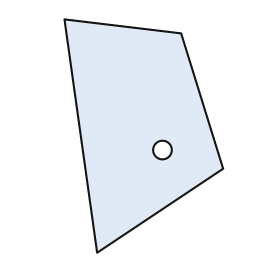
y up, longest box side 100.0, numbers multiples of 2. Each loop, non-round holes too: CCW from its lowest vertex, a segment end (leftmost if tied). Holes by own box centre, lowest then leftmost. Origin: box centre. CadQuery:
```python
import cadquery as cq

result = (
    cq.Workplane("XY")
    .moveTo(-20.0, -50.0)
    .lineTo(34.0, -14.0)
    .lineTo(16.0, 44.0)
    .lineTo(-34.0, 50.0)
    .close()
    .moveTo(8.0, -6.0)
    .circle(4.0)
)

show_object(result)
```